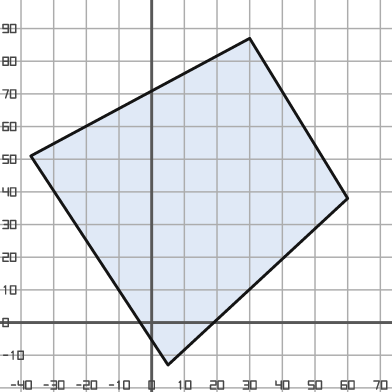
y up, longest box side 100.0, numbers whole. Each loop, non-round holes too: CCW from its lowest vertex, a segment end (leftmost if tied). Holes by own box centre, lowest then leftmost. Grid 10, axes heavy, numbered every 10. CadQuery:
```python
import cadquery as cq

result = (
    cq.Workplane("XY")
    .moveTo(5.0, -13.0)
    .lineTo(60.0, 38.0)
    .lineTo(30.0, 87.0)
    .lineTo(-37.0, 51.0)
    .close()
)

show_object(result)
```